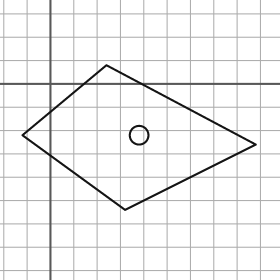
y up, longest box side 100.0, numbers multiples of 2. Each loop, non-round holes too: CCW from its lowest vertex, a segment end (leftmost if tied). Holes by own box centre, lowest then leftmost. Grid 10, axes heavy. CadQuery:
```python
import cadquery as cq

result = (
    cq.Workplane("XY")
    .moveTo(32.0, -54.0)
    .lineTo(88.0, -26.0)
    .lineTo(24.0, 8.0)
    .lineTo(-12.0, -22.0)
    .close()
    .moveTo(38.0, -22.0)
    .circle(4.0)
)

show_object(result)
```